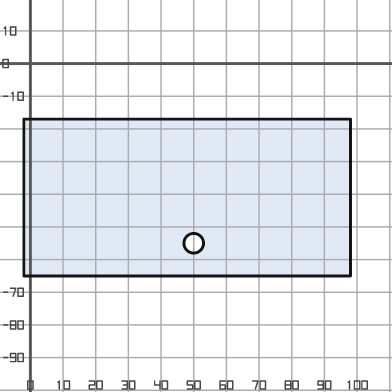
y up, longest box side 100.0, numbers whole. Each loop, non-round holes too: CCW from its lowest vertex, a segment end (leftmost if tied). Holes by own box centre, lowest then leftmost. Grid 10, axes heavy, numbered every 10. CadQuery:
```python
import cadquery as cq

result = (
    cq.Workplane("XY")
    .moveTo(-2.0, -65.0)
    .lineTo(98.0, -65.0)
    .lineTo(98.0, -17.0)
    .lineTo(-2.0, -17.0)
    .close()
    .moveTo(50.0, -55.0)
    .circle(3.0)
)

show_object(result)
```